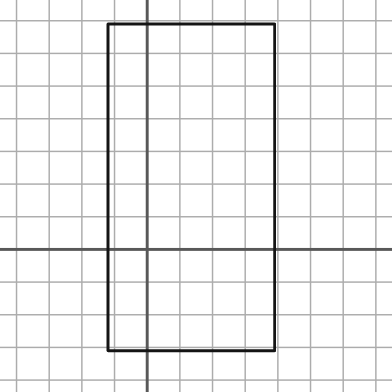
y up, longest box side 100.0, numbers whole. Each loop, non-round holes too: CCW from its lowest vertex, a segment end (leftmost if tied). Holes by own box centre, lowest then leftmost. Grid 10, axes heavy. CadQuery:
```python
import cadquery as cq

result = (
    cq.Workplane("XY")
    .moveTo(-12.0, -31.0)
    .lineTo(39.0, -31.0)
    .lineTo(39.0, 69.0)
    .lineTo(-12.0, 69.0)
    .close()
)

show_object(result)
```